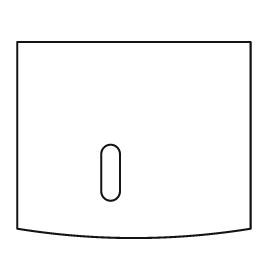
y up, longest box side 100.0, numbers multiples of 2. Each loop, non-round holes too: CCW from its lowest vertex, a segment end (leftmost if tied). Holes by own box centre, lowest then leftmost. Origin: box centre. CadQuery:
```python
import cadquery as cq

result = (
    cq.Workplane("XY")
    .moveTo(-50.0, -38.0)
    .threePointArc((0.0, -42.0), (50.0, -38.0))
    .lineTo(50.0, 42.0)
    .lineTo(-50.0, 42.0)
    .close()
    .moveTo(-14.0, -22.0)
    .threePointArc((-10.0, -26.0), (-6.0, -22.0))
    .lineTo(-6.0, -6.0)
    .threePointArc((-10.0, -2.0), (-14.0, -6.0))
    .close()
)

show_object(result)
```